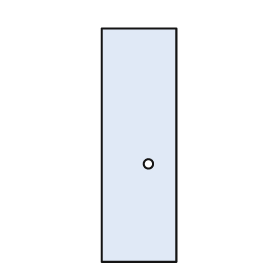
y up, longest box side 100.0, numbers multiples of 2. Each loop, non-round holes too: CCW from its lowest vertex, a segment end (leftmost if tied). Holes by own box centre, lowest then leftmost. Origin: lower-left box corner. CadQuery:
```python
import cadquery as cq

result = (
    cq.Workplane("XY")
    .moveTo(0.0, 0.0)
    .lineTo(32.0, 0.0)
    .lineTo(32.0, 100.0)
    .lineTo(0.0, 100.0)
    .close()
    .moveTo(20.0, 42.0)
    .circle(2.0)
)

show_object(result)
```